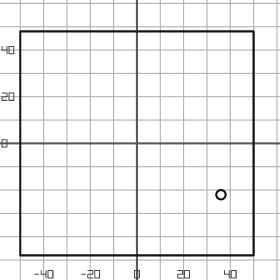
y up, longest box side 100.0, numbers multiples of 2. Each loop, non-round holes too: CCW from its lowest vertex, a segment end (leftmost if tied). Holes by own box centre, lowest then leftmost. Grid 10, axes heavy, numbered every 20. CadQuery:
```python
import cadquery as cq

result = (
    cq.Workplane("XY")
    .moveTo(-50.0, -48.0)
    .lineTo(50.0, -48.0)
    .lineTo(50.0, 48.0)
    .lineTo(-50.0, 48.0)
    .close()
    .moveTo(36.0, -22.0)
    .circle(2.0)
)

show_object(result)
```